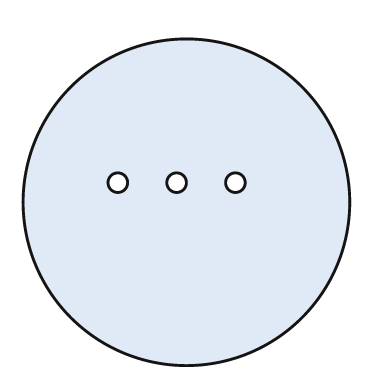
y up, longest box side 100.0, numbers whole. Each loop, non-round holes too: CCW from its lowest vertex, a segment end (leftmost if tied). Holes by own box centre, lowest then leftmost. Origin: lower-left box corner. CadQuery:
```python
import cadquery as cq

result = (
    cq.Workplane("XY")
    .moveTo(50.0, 50.0)
    .circle(50.0)
    .moveTo(29.0, 56.0)
    .circle(3.0)
    .moveTo(47.0, 56.0)
    .circle(3.0)
    .moveTo(65.0, 56.0)
    .circle(3.0)
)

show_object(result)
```